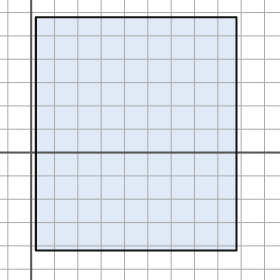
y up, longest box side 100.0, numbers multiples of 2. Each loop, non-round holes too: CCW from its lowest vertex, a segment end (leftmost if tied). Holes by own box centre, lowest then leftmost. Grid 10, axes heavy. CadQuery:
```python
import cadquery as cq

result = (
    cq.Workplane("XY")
    .moveTo(2.0, -42.0)
    .lineTo(88.0, -42.0)
    .lineTo(88.0, 58.0)
    .lineTo(2.0, 58.0)
    .close()
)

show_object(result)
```